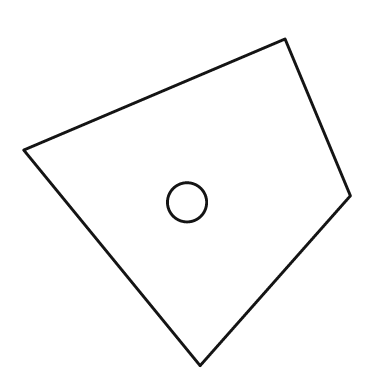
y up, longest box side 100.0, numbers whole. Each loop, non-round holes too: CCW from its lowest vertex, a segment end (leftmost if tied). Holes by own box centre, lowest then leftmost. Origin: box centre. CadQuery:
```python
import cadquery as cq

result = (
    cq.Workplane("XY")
    .moveTo(4.0, -50.0)
    .lineTo(50.0, 2.0)
    .lineTo(30.0, 50.0)
    .lineTo(-50.0, 16.0)
    .close()
    .moveTo(0.0, 0.0)
    .circle(6.0)
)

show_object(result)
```